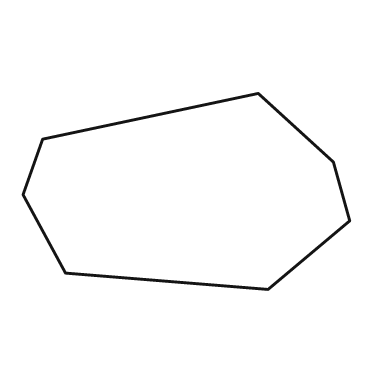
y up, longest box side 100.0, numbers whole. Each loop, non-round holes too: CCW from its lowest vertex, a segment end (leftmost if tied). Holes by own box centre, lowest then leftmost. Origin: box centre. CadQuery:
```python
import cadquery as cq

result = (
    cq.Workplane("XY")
    .moveTo(25.0, -30.0)
    .lineTo(50.0, -9.0)
    .lineTo(45.0, 9.0)
    .lineTo(22.0, 30.0)
    .lineTo(-44.0, 16.0)
    .lineTo(-50.0, -1.0)
    .lineTo(-37.0, -25.0)
    .close()
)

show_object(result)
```